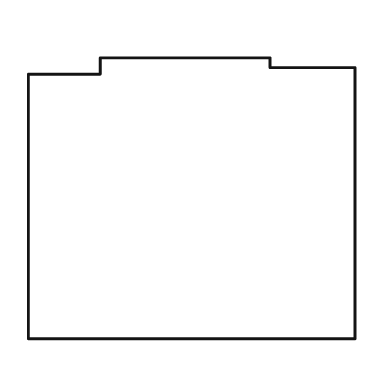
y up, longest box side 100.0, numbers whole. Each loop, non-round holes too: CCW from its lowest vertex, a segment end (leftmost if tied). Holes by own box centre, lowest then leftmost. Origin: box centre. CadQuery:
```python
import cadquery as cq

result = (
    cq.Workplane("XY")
    .moveTo(-50.0, -43.0)
    .lineTo(50.0, -43.0)
    .lineTo(50.0, 40.0)
    .lineTo(24.0, 40.0)
    .lineTo(24.0, 43.0)
    .lineTo(-28.0, 43.0)
    .lineTo(-28.0, 38.0)
    .lineTo(-50.0, 38.0)
    .close()
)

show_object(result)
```